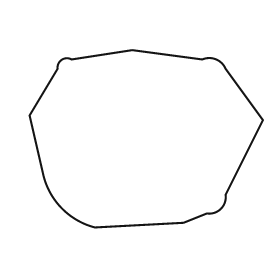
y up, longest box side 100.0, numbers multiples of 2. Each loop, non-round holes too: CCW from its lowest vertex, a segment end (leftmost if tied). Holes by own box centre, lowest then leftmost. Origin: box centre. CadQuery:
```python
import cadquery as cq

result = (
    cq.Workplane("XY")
    .moveTo(-22.0, -38.0)
    .lineTo(16.0, -36.0)
    .lineTo(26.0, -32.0)
    .threePointArc((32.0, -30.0), (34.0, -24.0))
    .lineTo(50.0, 8.0)
    .lineTo(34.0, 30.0)
    .threePointArc((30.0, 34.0), (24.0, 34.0))
    .lineTo(-6.0, 38.0)
    .lineTo(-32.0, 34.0)
    .threePointArc((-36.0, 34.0), (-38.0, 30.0))
    .lineTo(-50.0, 10.0)
    .lineTo(-44.0, -16.0)
    .threePointArc((-36.0, -30.0), (-22.0, -38.0))
    .close()
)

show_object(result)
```